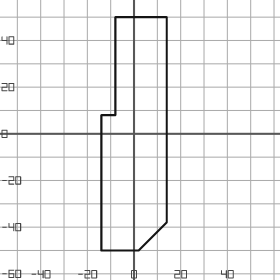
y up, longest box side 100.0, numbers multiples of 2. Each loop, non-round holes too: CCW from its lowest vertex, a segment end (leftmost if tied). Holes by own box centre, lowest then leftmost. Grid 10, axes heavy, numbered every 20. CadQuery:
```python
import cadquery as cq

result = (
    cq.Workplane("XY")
    .moveTo(-14.0, -50.0)
    .lineTo(2.0, -50.0)
    .lineTo(14.0, -38.0)
    .lineTo(14.0, 50.0)
    .lineTo(-8.0, 50.0)
    .lineTo(-8.0, 8.0)
    .lineTo(-14.0, 8.0)
    .close()
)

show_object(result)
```